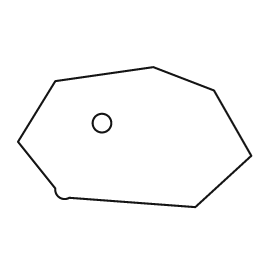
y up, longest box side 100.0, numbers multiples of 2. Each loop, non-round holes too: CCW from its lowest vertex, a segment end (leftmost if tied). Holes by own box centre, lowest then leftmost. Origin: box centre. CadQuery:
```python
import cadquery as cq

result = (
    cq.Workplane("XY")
    .moveTo(26.0, -30.0)
    .lineTo(50.0, -8.0)
    .lineTo(34.0, 20.0)
    .lineTo(8.0, 30.0)
    .lineTo(-34.0, 24.0)
    .lineTo(-50.0, -2.0)
    .lineTo(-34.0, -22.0)
    .threePointArc((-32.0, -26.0), (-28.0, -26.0))
    .close()
    .moveTo(-14.0, 6.0)
    .circle(4.0)
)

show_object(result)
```